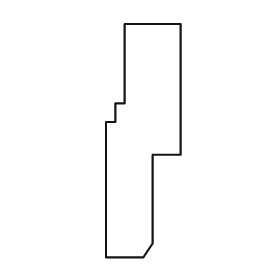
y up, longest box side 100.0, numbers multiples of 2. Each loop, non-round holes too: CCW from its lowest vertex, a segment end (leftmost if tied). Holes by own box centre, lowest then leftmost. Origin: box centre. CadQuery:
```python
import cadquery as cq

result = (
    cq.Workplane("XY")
    .moveTo(-16.0, -50.0)
    .lineTo(0.0, -50.0)
    .lineTo(4.0, -44.0)
    .lineTo(4.0, -6.0)
    .lineTo(16.0, -6.0)
    .lineTo(16.0, 50.0)
    .lineTo(-8.0, 50.0)
    .lineTo(-8.0, 16.0)
    .lineTo(-12.0, 16.0)
    .lineTo(-12.0, 8.0)
    .lineTo(-16.0, 8.0)
    .close()
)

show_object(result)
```